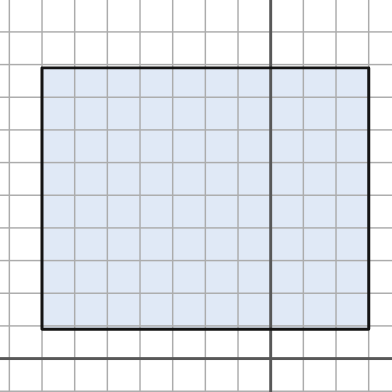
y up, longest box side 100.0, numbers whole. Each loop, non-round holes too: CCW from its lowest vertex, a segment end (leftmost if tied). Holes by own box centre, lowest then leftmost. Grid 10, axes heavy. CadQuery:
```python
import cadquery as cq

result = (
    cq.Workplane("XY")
    .moveTo(-70.0, 9.0)
    .lineTo(30.0, 9.0)
    .lineTo(30.0, 89.0)
    .lineTo(-70.0, 89.0)
    .close()
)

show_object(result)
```